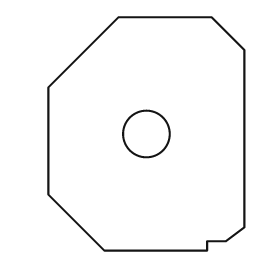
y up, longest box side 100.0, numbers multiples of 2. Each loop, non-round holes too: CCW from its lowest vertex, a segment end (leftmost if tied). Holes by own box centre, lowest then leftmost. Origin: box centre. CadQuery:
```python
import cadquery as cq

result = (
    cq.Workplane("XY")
    .moveTo(-18.0, -50.0)
    .lineTo(26.0, -50.0)
    .lineTo(26.0, -46.0)
    .lineTo(34.0, -46.0)
    .lineTo(42.0, -40.0)
    .lineTo(42.0, 36.0)
    .lineTo(28.0, 50.0)
    .lineTo(-12.0, 50.0)
    .lineTo(-42.0, 20.0)
    .lineTo(-42.0, -26.0)
    .close()
    .moveTo(0.0, 0.0)
    .circle(10.0)
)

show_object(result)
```